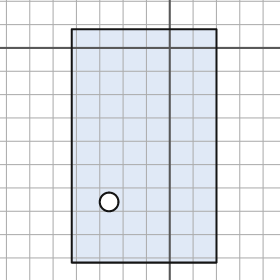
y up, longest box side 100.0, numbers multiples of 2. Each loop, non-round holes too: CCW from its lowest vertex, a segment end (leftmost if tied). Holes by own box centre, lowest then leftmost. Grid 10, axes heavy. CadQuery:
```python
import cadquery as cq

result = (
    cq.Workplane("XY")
    .moveTo(-42.0, -92.0)
    .lineTo(20.0, -92.0)
    .lineTo(20.0, 8.0)
    .lineTo(-42.0, 8.0)
    .close()
    .moveTo(-26.0, -66.0)
    .circle(4.0)
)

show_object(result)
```